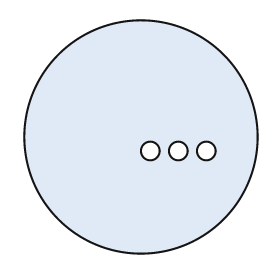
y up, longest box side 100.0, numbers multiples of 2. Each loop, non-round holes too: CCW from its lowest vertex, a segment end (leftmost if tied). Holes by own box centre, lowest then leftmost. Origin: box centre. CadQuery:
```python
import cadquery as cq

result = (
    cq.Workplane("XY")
    .moveTo(0.0, 0.0)
    .circle(50.0)
    .moveTo(4.0, -6.0)
    .circle(4.0)
    .moveTo(16.0, -6.0)
    .circle(4.0)
    .moveTo(28.0, -6.0)
    .circle(4.0)
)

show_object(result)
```